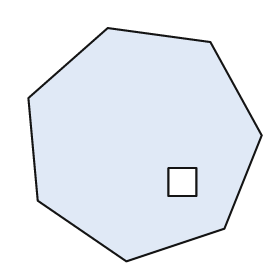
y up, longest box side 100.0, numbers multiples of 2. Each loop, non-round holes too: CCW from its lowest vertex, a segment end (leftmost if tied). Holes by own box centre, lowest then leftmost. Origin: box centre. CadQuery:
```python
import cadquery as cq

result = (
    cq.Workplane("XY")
    .moveTo(-8.0, -50.0)
    .lineTo(34.0, -36.0)
    .lineTo(50.0, 4.0)
    .lineTo(28.0, 44.0)
    .lineTo(-16.0, 50.0)
    .lineTo(-50.0, 20.0)
    .lineTo(-46.0, -24.0)
    .close()
    .moveTo(10.0, -22.0)
    .lineTo(22.0, -22.0)
    .lineTo(22.0, -10.0)
    .lineTo(10.0, -10.0)
    .close()
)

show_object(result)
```